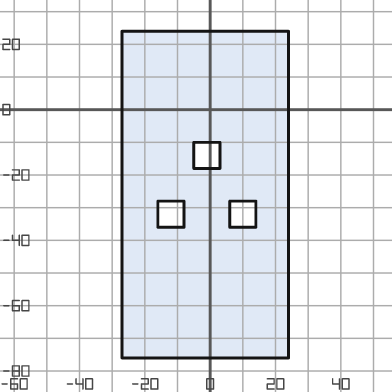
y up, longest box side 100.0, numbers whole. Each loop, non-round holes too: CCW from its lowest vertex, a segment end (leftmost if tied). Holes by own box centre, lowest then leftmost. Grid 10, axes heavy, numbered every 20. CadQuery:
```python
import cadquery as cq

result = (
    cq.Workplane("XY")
    .moveTo(-27.0, -76.0)
    .lineTo(24.0, -76.0)
    .lineTo(24.0, 24.0)
    .lineTo(-27.0, 24.0)
    .close()
    .moveTo(-16.0, -36.0)
    .lineTo(-8.0, -36.0)
    .lineTo(-8.0, -28.0)
    .lineTo(-16.0, -28.0)
    .close()
    .moveTo(6.0, -36.0)
    .lineTo(14.0, -36.0)
    .lineTo(14.0, -28.0)
    .lineTo(6.0, -28.0)
    .close()
    .moveTo(-5.0, -18.0)
    .lineTo(3.0, -18.0)
    .lineTo(3.0, -10.0)
    .lineTo(-5.0, -10.0)
    .close()
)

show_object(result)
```